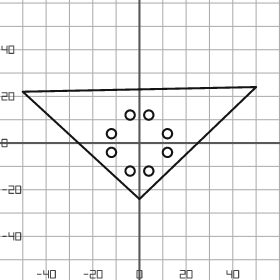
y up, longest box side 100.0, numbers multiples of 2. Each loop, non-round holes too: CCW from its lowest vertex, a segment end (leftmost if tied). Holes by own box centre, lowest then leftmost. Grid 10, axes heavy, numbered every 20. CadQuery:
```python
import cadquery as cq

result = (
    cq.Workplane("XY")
    .moveTo(0.0, -24.0)
    .lineTo(50.0, 24.0)
    .lineTo(-50.0, 22.0)
    .close()
    .moveTo(-4.0, -12.0)
    .circle(2.0)
    .moveTo(4.0, -12.0)
    .circle(2.0)
    .moveTo(-12.0, -4.0)
    .circle(2.0)
    .moveTo(12.0, -4.0)
    .circle(2.0)
    .moveTo(-12.0, 4.0)
    .circle(2.0)
    .moveTo(12.0, 4.0)
    .circle(2.0)
    .moveTo(-4.0, 12.0)
    .circle(2.0)
    .moveTo(4.0, 12.0)
    .circle(2.0)
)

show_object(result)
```